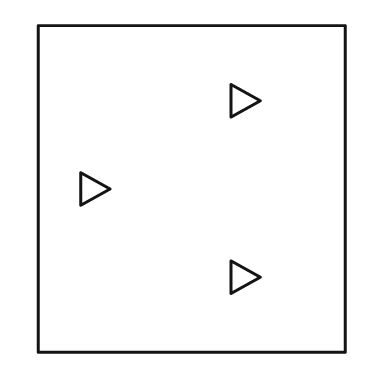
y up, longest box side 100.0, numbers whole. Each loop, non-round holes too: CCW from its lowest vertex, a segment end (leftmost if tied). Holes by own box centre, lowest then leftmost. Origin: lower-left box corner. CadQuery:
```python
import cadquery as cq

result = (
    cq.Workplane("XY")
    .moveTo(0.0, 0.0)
    .lineTo(94.0, 0.0)
    .lineTo(94.0, 100.0)
    .lineTo(0.0, 100.0)
    .close()
    .moveTo(59.0, 18.0)
    .lineTo(68.0, 23.0)
    .lineTo(59.0, 28.0)
    .close()
    .moveTo(13.0, 45.0)
    .lineTo(22.0, 50.0)
    .lineTo(13.0, 55.0)
    .close()
    .moveTo(59.0, 72.0)
    .lineTo(68.0, 77.0)
    .lineTo(59.0, 82.0)
    .close()
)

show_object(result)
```